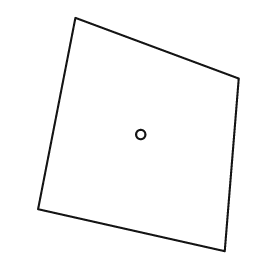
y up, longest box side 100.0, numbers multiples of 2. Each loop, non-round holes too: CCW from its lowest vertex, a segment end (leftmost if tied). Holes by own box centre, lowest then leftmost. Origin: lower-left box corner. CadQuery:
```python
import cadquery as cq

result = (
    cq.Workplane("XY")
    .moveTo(80.0, 0.0)
    .lineTo(86.0, 74.0)
    .lineTo(16.0, 100.0)
    .lineTo(0.0, 18.0)
    .close()
    .moveTo(44.0, 50.0)
    .circle(2.0)
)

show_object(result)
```